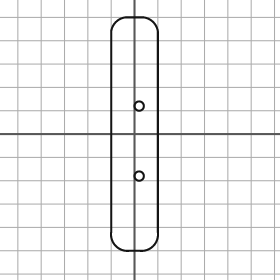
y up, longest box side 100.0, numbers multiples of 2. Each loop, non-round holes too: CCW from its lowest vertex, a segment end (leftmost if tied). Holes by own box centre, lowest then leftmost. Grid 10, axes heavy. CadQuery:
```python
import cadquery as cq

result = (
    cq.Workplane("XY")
    .moveTo(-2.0, -50.0)
    .lineTo(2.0, -50.0)
    .threePointArc((8.0, -48.0), (10.0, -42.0))
    .lineTo(10.0, 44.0)
    .threePointArc((8.0, 48.0), (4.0, 50.0))
    .lineTo(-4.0, 50.0)
    .threePointArc((-8.0, 48.0), (-10.0, 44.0))
    .lineTo(-10.0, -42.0)
    .threePointArc((-8.0, -48.0), (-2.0, -50.0))
    .close()
    .moveTo(2.0, -18.0)
    .circle(2.0)
    .moveTo(2.0, 12.0)
    .circle(2.0)
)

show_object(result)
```